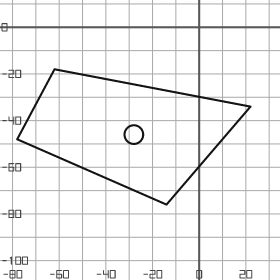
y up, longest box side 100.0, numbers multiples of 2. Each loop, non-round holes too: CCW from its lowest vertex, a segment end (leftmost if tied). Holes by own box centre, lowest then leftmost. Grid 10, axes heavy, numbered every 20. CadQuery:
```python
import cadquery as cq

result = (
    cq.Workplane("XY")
    .moveTo(-14.0, -76.0)
    .lineTo(22.0, -34.0)
    .lineTo(-62.0, -18.0)
    .lineTo(-78.0, -48.0)
    .close()
    .moveTo(-28.0, -46.0)
    .circle(4.0)
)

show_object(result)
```